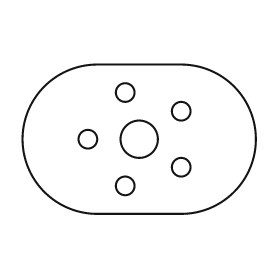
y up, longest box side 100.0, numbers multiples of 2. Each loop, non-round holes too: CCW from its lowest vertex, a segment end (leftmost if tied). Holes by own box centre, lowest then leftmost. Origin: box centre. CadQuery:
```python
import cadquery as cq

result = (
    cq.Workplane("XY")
    .moveTo(-18.0, -32.0)
    .lineTo(18.0, -32.0)
    .threePointArc((50.0, 0.0), (18.0, 32.0))
    .lineTo(-18.0, 32.0)
    .threePointArc((-50.0, 0.0), (-18.0, -32.0))
    .close()
    .moveTo(-6.0, -20.0)
    .circle(4.0)
    .moveTo(18.0, -12.0)
    .circle(4.0)
    .moveTo(-22.0, 0.0)
    .circle(4.0)
    .moveTo(0.0, 0.0)
    .circle(8.0)
    .moveTo(18.0, 12.0)
    .circle(4.0)
    .moveTo(-6.0, 20.0)
    .circle(4.0)
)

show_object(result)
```